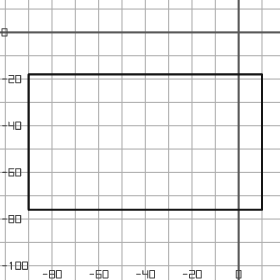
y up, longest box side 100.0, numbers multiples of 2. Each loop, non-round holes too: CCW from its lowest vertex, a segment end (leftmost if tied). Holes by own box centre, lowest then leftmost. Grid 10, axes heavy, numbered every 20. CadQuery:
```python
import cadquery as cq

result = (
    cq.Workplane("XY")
    .moveTo(-90.0, -76.0)
    .lineTo(10.0, -76.0)
    .lineTo(10.0, -18.0)
    .lineTo(-90.0, -18.0)
    .close()
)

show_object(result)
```